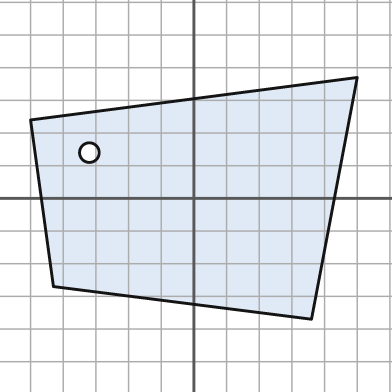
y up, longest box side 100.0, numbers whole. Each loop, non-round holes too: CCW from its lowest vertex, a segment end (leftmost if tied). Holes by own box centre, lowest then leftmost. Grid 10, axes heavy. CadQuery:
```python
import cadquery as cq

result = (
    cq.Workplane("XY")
    .moveTo(36.0, -37.0)
    .lineTo(50.0, 37.0)
    .lineTo(-50.0, 24.0)
    .lineTo(-43.0, -27.0)
    .close()
    .moveTo(-32.0, 14.0)
    .circle(3.0)
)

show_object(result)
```